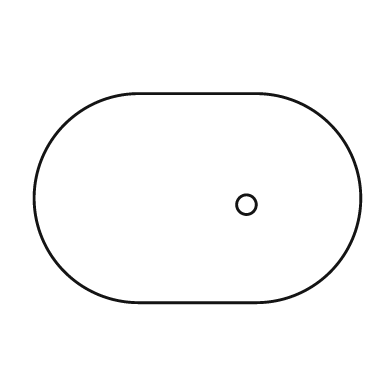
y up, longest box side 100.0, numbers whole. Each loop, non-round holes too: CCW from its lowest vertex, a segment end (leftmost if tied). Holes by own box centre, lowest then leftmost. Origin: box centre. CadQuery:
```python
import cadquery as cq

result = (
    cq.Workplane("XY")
    .moveTo(-18.0, -32.0)
    .lineTo(18.0, -32.0)
    .threePointArc((50.0, 0.0), (18.0, 32.0))
    .lineTo(-18.0, 32.0)
    .threePointArc((-50.0, 0.0), (-18.0, -32.0))
    .close()
    .moveTo(15.0, -2.0)
    .circle(3.0)
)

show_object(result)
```